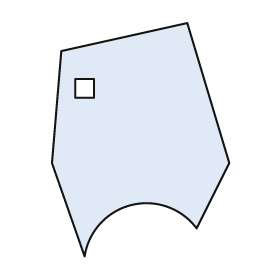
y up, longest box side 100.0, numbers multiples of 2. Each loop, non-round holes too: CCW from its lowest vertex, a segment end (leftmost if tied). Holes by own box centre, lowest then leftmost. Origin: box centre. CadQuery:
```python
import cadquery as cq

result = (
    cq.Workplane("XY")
    .moveTo(-24.0, -50.0)
    .threePointArc((-4.0, -28.0), (24.0, -38.0))
    .lineTo(38.0, -10.0)
    .lineTo(20.0, 50.0)
    .lineTo(-34.0, 38.0)
    .lineTo(-38.0, -10.0)
    .close()
    .moveTo(-28.0, 18.0)
    .lineTo(-20.0, 18.0)
    .lineTo(-20.0, 26.0)
    .lineTo(-28.0, 26.0)
    .close()
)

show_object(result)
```